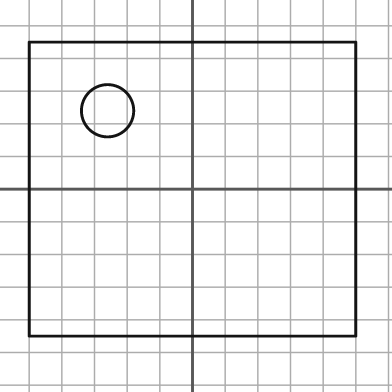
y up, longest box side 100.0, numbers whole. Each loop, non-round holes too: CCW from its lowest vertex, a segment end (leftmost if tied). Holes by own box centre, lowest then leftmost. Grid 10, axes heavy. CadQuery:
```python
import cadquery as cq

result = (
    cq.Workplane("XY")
    .moveTo(-50.0, -45.0)
    .lineTo(50.0, -45.0)
    .lineTo(50.0, 45.0)
    .lineTo(-50.0, 45.0)
    .close()
    .moveTo(-26.0, 24.0)
    .circle(8.0)
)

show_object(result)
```